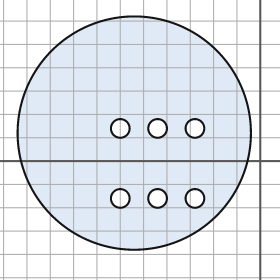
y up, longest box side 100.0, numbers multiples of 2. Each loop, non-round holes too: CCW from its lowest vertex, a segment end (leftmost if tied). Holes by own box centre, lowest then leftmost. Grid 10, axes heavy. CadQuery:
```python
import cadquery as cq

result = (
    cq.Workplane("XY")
    .moveTo(-54.0, 12.0)
    .circle(50.0)
    .moveTo(-60.0, -16.0)
    .circle(4.0)
    .moveTo(-44.0, -16.0)
    .circle(4.0)
    .moveTo(-28.0, -16.0)
    .circle(4.0)
    .moveTo(-60.0, 14.0)
    .circle(4.0)
    .moveTo(-44.0, 14.0)
    .circle(4.0)
    .moveTo(-28.0, 14.0)
    .circle(4.0)
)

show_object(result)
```